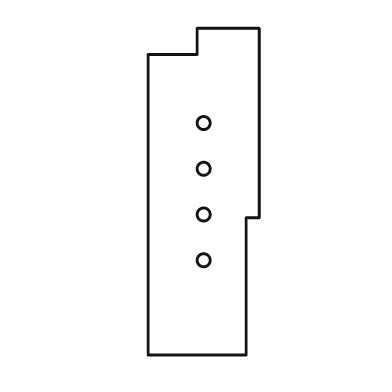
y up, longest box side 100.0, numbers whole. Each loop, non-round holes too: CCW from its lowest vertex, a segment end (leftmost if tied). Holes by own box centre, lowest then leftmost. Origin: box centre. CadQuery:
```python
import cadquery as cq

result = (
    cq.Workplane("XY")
    .moveTo(-17.0, -50.0)
    .lineTo(13.0, -50.0)
    .lineTo(13.0, -8.0)
    .lineTo(17.0, -8.0)
    .lineTo(17.0, 50.0)
    .lineTo(-2.0, 50.0)
    .lineTo(-2.0, 42.0)
    .lineTo(-17.0, 42.0)
    .close()
    .moveTo(0.0, -21.0)
    .circle(2.0)
    .moveTo(0.0, -7.0)
    .circle(2.0)
    .moveTo(0.0, 7.0)
    .circle(2.0)
    .moveTo(0.0, 21.0)
    .circle(2.0)
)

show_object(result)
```